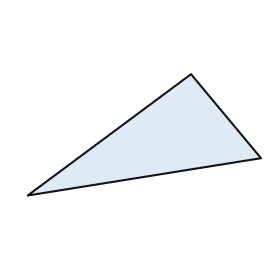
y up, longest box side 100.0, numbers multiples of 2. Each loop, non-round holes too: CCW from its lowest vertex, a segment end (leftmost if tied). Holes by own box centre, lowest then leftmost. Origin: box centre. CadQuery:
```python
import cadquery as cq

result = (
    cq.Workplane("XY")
    .moveTo(-50.0, -26.0)
    .lineTo(50.0, -10.0)
    .lineTo(20.0, 26.0)
    .close()
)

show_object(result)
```